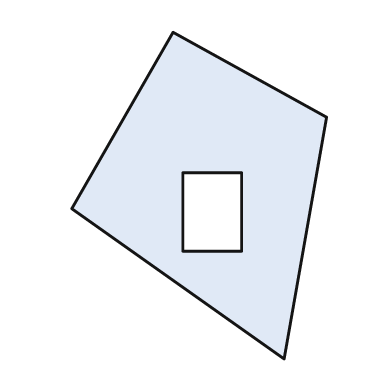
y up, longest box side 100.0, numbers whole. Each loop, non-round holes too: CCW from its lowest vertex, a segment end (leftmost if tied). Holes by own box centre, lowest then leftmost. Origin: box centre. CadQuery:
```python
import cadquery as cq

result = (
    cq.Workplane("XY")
    .moveTo(26.0, -50.0)
    .lineTo(39.0, 24.0)
    .lineTo(-8.0, 50.0)
    .lineTo(-39.0, -4.0)
    .close()
    .moveTo(-5.0, -17.0)
    .lineTo(13.0, -17.0)
    .lineTo(13.0, 7.0)
    .lineTo(-5.0, 7.0)
    .close()
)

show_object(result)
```